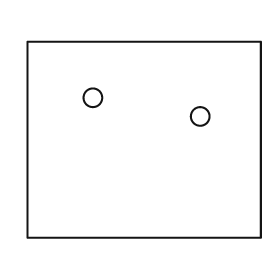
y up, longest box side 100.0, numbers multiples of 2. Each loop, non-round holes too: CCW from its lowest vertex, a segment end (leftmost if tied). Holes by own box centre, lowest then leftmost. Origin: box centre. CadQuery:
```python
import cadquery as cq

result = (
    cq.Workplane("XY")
    .moveTo(-50.0, -42.0)
    .lineTo(50.0, -42.0)
    .lineTo(50.0, 42.0)
    .lineTo(-50.0, 42.0)
    .close()
    .moveTo(24.0, 10.0)
    .circle(4.0)
    .moveTo(-22.0, 18.0)
    .circle(4.0)
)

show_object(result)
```